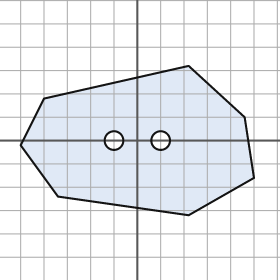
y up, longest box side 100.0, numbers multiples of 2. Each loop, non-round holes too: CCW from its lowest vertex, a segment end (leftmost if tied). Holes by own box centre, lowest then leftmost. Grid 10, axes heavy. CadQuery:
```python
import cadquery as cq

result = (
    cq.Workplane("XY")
    .moveTo(22.0, -32.0)
    .lineTo(50.0, -16.0)
    .lineTo(46.0, 10.0)
    .lineTo(22.0, 32.0)
    .lineTo(-40.0, 18.0)
    .lineTo(-50.0, -2.0)
    .lineTo(-34.0, -24.0)
    .close()
    .moveTo(-10.0, 0.0)
    .circle(4.0)
    .moveTo(10.0, 0.0)
    .circle(4.0)
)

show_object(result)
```